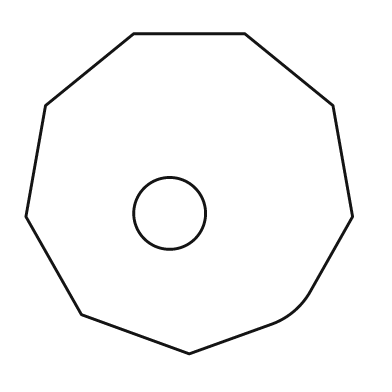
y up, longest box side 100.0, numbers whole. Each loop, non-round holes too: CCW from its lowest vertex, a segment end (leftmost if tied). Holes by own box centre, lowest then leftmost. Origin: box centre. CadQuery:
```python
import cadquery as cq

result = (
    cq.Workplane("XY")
    .moveTo(0.0, -49.0)
    .lineTo(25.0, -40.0)
    .threePointArc((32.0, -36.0), (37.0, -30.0))
    .lineTo(50.0, -7.0)
    .lineTo(44.0, 27.0)
    .lineTo(17.0, 49.0)
    .lineTo(-17.0, 49.0)
    .lineTo(-44.0, 27.0)
    .lineTo(-50.0, -7.0)
    .lineTo(-33.0, -37.0)
    .close()
    .moveTo(-6.0, -6.0)
    .circle(11.0)
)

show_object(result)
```